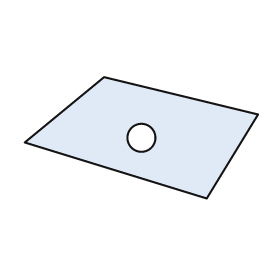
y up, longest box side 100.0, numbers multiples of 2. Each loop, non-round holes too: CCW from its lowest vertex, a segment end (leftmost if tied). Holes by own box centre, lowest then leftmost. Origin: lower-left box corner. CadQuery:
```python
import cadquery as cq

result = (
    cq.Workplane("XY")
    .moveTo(78.0, 0.0)
    .lineTo(100.0, 36.0)
    .lineTo(34.0, 52.0)
    .lineTo(0.0, 24.0)
    .close()
    .moveTo(50.0, 26.0)
    .circle(6.0)
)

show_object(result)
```